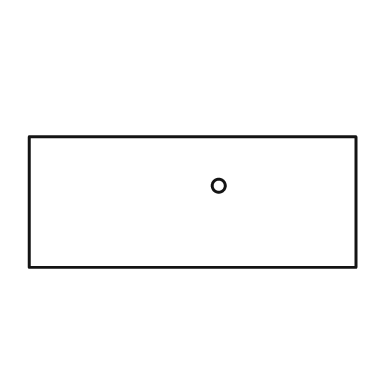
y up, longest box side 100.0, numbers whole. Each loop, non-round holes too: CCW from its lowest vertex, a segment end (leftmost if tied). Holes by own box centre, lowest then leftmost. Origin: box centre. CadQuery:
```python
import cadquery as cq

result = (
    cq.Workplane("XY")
    .moveTo(-50.0, -20.0)
    .lineTo(50.0, -20.0)
    .lineTo(50.0, 20.0)
    .lineTo(-50.0, 20.0)
    .close()
    .moveTo(8.0, 5.0)
    .circle(2.0)
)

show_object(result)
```